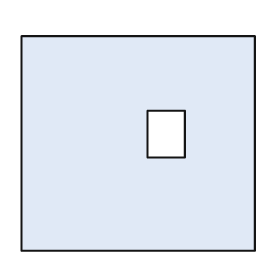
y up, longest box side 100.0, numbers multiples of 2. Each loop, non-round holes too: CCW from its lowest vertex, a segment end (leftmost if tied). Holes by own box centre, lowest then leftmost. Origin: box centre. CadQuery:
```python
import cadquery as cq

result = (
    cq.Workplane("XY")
    .moveTo(-50.0, -46.0)
    .lineTo(50.0, -46.0)
    .lineTo(50.0, 46.0)
    .lineTo(-50.0, 46.0)
    .close()
    .moveTo(4.0, -6.0)
    .lineTo(20.0, -6.0)
    .lineTo(20.0, 14.0)
    .lineTo(4.0, 14.0)
    .close()
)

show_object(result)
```